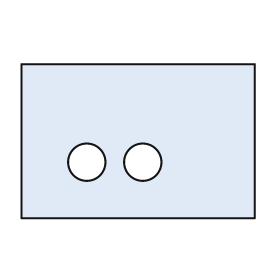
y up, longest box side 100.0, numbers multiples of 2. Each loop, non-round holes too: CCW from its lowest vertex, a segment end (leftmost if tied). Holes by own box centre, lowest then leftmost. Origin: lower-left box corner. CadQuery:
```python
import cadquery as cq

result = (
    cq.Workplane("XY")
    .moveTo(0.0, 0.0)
    .lineTo(100.0, 0.0)
    .lineTo(100.0, 66.0)
    .lineTo(0.0, 66.0)
    .close()
    .moveTo(28.0, 24.0)
    .circle(8.0)
    .moveTo(52.0, 24.0)
    .circle(8.0)
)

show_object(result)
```